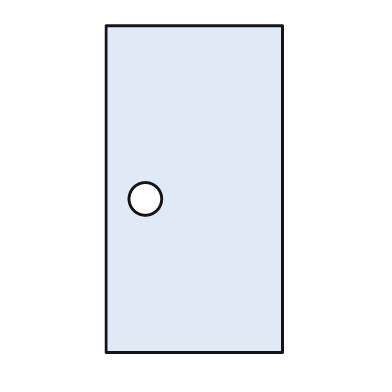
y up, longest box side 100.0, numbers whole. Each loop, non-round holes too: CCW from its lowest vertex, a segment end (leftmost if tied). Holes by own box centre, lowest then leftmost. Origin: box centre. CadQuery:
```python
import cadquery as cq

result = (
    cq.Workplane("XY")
    .moveTo(-27.0, -50.0)
    .lineTo(27.0, -50.0)
    .lineTo(27.0, 50.0)
    .lineTo(-27.0, 50.0)
    .close()
    .moveTo(-15.0, -3.0)
    .circle(5.0)
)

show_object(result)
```